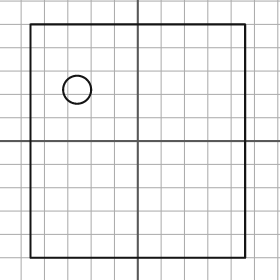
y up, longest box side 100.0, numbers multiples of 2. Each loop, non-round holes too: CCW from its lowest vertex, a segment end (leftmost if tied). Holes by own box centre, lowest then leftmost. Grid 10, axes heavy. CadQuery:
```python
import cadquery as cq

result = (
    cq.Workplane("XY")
    .moveTo(-46.0, -50.0)
    .lineTo(46.0, -50.0)
    .lineTo(46.0, 50.0)
    .lineTo(-46.0, 50.0)
    .close()
    .moveTo(-26.0, 22.0)
    .circle(6.0)
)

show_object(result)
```